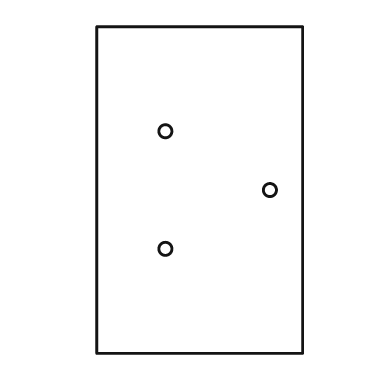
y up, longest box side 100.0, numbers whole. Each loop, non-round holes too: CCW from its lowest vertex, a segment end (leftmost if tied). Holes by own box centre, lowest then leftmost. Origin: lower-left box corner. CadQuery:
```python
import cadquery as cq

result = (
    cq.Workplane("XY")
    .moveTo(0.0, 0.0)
    .lineTo(63.0, 0.0)
    .lineTo(63.0, 100.0)
    .lineTo(0.0, 100.0)
    .close()
    .moveTo(21.0, 32.0)
    .circle(2.0)
    .moveTo(53.0, 50.0)
    .circle(2.0)
    .moveTo(21.0, 68.0)
    .circle(2.0)
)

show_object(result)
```